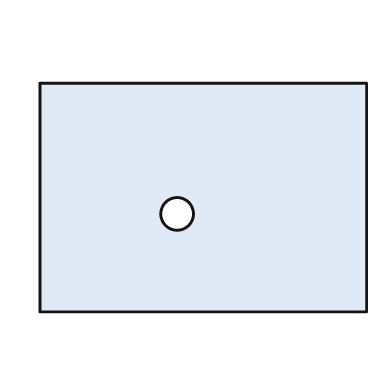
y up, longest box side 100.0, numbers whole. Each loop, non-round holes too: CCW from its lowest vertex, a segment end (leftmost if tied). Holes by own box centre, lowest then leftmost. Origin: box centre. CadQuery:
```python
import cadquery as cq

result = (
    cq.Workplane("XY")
    .moveTo(-50.0, -35.0)
    .lineTo(50.0, -35.0)
    .lineTo(50.0, 35.0)
    .lineTo(-50.0, 35.0)
    .close()
    .moveTo(-8.0, -5.0)
    .circle(5.0)
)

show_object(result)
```